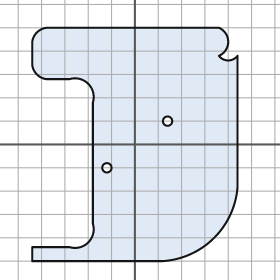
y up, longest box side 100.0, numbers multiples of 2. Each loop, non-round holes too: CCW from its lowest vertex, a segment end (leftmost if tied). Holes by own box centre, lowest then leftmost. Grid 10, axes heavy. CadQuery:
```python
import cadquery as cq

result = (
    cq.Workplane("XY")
    .moveTo(-44.0, -50.0)
    .lineTo(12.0, -50.0)
    .threePointArc((34.0, -40.0), (44.0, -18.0))
    .lineTo(44.0, 38.0)
    .threePointArc((40.0, 36.0), (36.0, 38.0))
    .threePointArc((40.0, 44.0), (36.0, 50.0))
    .lineTo(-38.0, 50.0)
    .threePointArc((-42.0, 48.0), (-44.0, 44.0))
    .lineTo(-44.0, 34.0)
    .threePointArc((-42.0, 30.0), (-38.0, 28.0))
    .lineTo(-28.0, 28.0)
    .threePointArc((-20.0, 26.0), (-18.0, 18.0))
    .lineTo(-18.0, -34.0)
    .threePointArc((-20.0, -42.0), (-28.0, -44.0))
    .lineTo(-44.0, -44.0)
    .close()
    .moveTo(-12.0, -10.0)
    .circle(2.0)
    .moveTo(14.0, 10.0)
    .circle(2.0)
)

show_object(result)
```